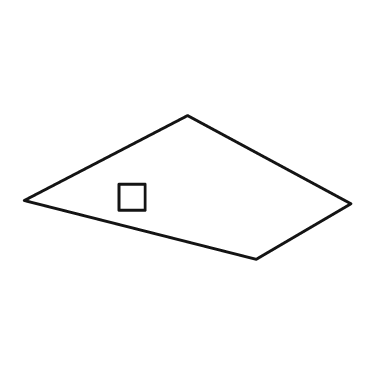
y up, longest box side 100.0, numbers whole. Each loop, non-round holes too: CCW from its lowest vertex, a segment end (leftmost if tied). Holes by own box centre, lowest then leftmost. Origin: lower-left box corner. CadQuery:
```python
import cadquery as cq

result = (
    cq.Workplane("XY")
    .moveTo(71.0, 0.0)
    .lineTo(100.0, 17.0)
    .lineTo(50.0, 44.0)
    .lineTo(0.0, 18.0)
    .close()
    .moveTo(29.0, 15.0)
    .lineTo(37.0, 15.0)
    .lineTo(37.0, 23.0)
    .lineTo(29.0, 23.0)
    .close()
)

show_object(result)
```